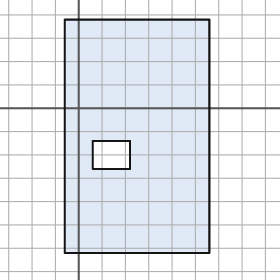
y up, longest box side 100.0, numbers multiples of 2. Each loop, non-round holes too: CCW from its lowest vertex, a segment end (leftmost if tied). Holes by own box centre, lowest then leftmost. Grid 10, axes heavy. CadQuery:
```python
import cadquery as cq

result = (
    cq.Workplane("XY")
    .moveTo(-6.0, -62.0)
    .lineTo(56.0, -62.0)
    .lineTo(56.0, 38.0)
    .lineTo(-6.0, 38.0)
    .close()
    .moveTo(6.0, -26.0)
    .lineTo(22.0, -26.0)
    .lineTo(22.0, -14.0)
    .lineTo(6.0, -14.0)
    .close()
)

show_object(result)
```